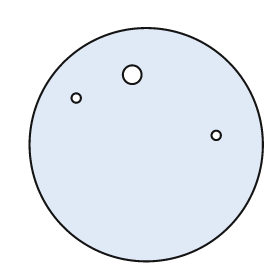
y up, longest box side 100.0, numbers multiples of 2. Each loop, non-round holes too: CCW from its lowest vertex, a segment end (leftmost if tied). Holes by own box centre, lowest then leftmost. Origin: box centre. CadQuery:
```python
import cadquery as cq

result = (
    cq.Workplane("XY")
    .moveTo(0.0, 0.0)
    .circle(50.0)
    .moveTo(30.0, 4.0)
    .circle(2.0)
    .moveTo(-30.0, 20.0)
    .circle(2.0)
    .moveTo(-6.0, 30.0)
    .circle(4.0)
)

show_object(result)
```